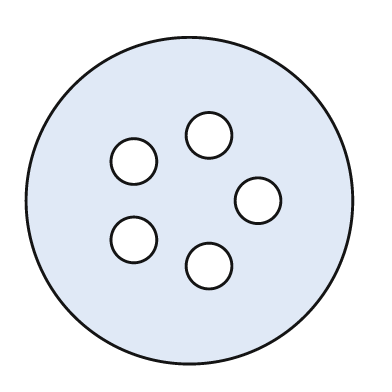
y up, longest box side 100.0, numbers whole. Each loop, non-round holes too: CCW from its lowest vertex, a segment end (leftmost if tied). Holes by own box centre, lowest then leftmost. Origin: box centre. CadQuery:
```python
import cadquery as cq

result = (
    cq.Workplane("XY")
    .moveTo(0.0, 0.0)
    .circle(50.0)
    .moveTo(6.0, -20.0)
    .circle(7.0)
    .moveTo(-17.0, -12.0)
    .circle(7.0)
    .moveTo(21.0, 0.0)
    .circle(7.0)
    .moveTo(-17.0, 12.0)
    .circle(7.0)
    .moveTo(6.0, 20.0)
    .circle(7.0)
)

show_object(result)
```